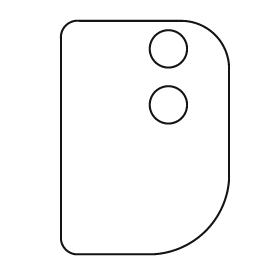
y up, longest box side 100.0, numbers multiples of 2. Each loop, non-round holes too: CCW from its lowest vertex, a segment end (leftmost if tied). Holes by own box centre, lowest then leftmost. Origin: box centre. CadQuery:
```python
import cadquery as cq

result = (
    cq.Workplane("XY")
    .moveTo(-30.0, -50.0)
    .lineTo(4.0, -50.0)
    .threePointArc((26.0, -40.0), (36.0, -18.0))
    .lineTo(36.0, 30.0)
    .threePointArc((30.0, 44.0), (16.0, 50.0))
    .lineTo(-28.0, 50.0)
    .threePointArc((-34.0, 48.0), (-36.0, 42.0))
    .lineTo(-36.0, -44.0)
    .threePointArc((-34.0, -48.0), (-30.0, -50.0))
    .close()
    .moveTo(10.0, 14.0)
    .circle(8.0)
    .moveTo(10.0, 38.0)
    .circle(8.0)
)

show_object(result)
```